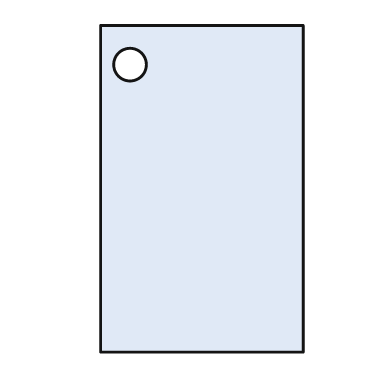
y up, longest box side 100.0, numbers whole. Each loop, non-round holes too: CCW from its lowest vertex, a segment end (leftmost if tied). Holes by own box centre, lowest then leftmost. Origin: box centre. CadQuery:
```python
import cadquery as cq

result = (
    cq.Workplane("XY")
    .moveTo(-31.0, -50.0)
    .lineTo(31.0, -50.0)
    .lineTo(31.0, 50.0)
    .lineTo(-31.0, 50.0)
    .close()
    .moveTo(-22.0, 38.0)
    .circle(5.0)
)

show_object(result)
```